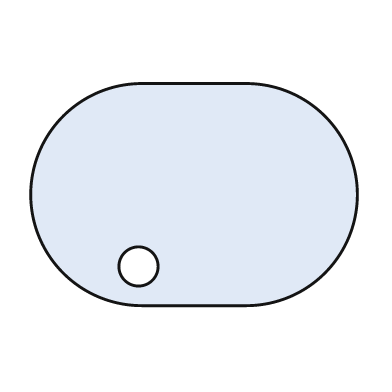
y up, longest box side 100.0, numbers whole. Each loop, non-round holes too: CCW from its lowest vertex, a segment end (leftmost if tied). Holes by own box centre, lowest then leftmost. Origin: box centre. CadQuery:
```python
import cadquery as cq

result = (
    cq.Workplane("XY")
    .moveTo(-16.0, -34.0)
    .lineTo(16.0, -34.0)
    .threePointArc((50.0, 0.0), (16.0, 34.0))
    .lineTo(-16.0, 34.0)
    .threePointArc((-50.0, 0.0), (-16.0, -34.0))
    .close()
    .moveTo(-17.0, -22.0)
    .circle(6.0)
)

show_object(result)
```